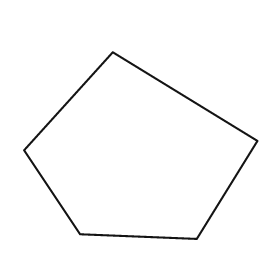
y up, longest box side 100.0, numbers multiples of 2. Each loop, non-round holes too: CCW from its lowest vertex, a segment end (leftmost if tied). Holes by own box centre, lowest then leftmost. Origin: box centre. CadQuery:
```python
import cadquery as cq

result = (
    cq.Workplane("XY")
    .moveTo(24.0, -40.0)
    .lineTo(50.0, 2.0)
    .lineTo(-12.0, 40.0)
    .lineTo(-50.0, -2.0)
    .lineTo(-26.0, -38.0)
    .close()
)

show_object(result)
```